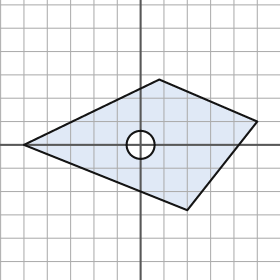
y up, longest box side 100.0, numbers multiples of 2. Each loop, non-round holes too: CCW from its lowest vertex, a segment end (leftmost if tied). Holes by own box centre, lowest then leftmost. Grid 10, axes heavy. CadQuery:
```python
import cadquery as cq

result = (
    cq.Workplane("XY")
    .moveTo(20.0, -28.0)
    .lineTo(50.0, 10.0)
    .lineTo(8.0, 28.0)
    .lineTo(-50.0, 0.0)
    .close()
    .moveTo(0.0, 0.0)
    .circle(6.0)
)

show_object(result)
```